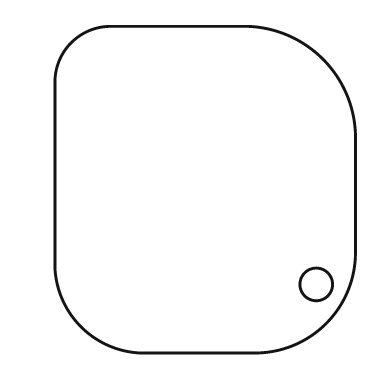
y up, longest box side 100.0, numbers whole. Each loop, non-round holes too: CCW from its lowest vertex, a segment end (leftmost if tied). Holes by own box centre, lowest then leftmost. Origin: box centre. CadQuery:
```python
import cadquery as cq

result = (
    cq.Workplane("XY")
    .moveTo(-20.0, -50.0)
    .lineTo(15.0, -50.0)
    .threePointArc((37.0, -41.0), (46.0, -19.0))
    .lineTo(46.0, 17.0)
    .threePointArc((36.0, 40.0), (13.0, 50.0))
    .lineTo(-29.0, 50.0)
    .threePointArc((-41.0, 45.0), (-46.0, 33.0))
    .lineTo(-46.0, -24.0)
    .threePointArc((-38.0, -42.0), (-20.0, -50.0))
    .close()
    .moveTo(34.0, -29.0)
    .circle(5.0)
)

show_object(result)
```